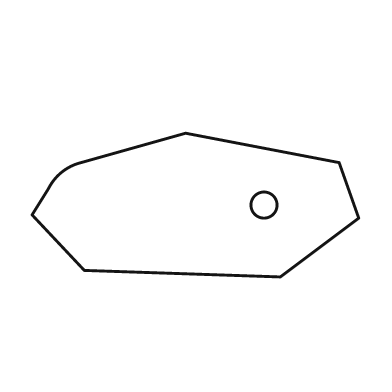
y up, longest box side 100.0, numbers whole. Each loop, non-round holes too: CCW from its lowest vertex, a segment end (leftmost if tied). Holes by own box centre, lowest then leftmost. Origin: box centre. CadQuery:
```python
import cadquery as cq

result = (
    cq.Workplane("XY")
    .moveTo(26.0, -22.0)
    .lineTo(50.0, -4.0)
    .lineTo(44.0, 13.0)
    .lineTo(-3.0, 22.0)
    .lineTo(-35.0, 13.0)
    .threePointArc((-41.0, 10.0), (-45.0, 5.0))
    .lineTo(-50.0, -3.0)
    .lineTo(-34.0, -20.0)
    .close()
    .moveTo(21.0, 0.0)
    .circle(4.0)
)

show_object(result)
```